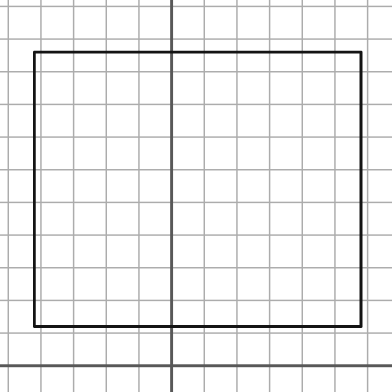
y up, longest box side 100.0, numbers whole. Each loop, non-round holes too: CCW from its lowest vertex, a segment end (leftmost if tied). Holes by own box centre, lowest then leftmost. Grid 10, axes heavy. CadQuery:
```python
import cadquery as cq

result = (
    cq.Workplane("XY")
    .moveTo(-42.0, 12.0)
    .lineTo(58.0, 12.0)
    .lineTo(58.0, 96.0)
    .lineTo(-42.0, 96.0)
    .close()
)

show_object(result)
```